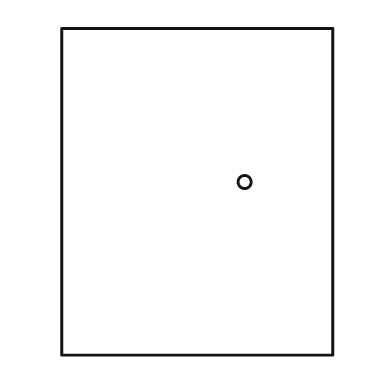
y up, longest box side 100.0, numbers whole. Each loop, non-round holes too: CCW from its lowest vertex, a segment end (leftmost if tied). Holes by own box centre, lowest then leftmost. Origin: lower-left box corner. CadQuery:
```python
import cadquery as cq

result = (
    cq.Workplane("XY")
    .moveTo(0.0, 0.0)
    .lineTo(83.0, 0.0)
    .lineTo(83.0, 100.0)
    .lineTo(0.0, 100.0)
    .close()
    .moveTo(56.0, 53.0)
    .circle(2.0)
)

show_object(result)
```